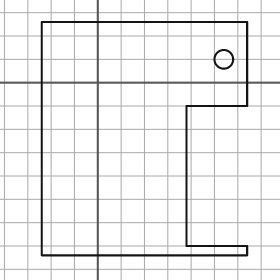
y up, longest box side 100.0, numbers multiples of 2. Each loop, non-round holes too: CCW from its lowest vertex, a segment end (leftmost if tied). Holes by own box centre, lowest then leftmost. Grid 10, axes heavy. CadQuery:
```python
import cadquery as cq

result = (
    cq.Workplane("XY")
    .moveTo(-24.0, -74.0)
    .lineTo(64.0, -74.0)
    .lineTo(64.0, -70.0)
    .lineTo(38.0, -70.0)
    .lineTo(38.0, -10.0)
    .lineTo(64.0, -10.0)
    .lineTo(64.0, 26.0)
    .lineTo(-24.0, 26.0)
    .close()
    .moveTo(54.0, 10.0)
    .circle(4.0)
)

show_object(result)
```